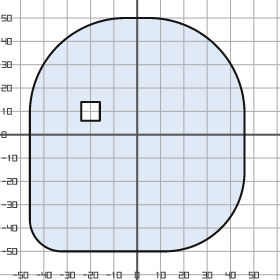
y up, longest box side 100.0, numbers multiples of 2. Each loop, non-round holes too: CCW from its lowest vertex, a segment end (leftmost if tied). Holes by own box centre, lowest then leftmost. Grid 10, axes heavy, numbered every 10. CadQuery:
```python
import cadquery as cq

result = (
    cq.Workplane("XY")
    .moveTo(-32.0, -50.0)
    .lineTo(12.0, -50.0)
    .threePointArc((36.0, -40.0), (46.0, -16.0))
    .lineTo(46.0, 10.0)
    .threePointArc((34.0, 38.0), (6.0, 50.0))
    .lineTo(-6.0, 50.0)
    .threePointArc((-34.0, 38.0), (-46.0, 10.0))
    .lineTo(-46.0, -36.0)
    .threePointArc((-42.0, -46.0), (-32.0, -50.0))
    .close()
    .moveTo(-24.0, 6.0)
    .lineTo(-16.0, 6.0)
    .lineTo(-16.0, 14.0)
    .lineTo(-24.0, 14.0)
    .close()
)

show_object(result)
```